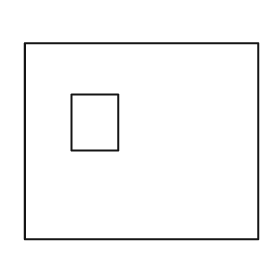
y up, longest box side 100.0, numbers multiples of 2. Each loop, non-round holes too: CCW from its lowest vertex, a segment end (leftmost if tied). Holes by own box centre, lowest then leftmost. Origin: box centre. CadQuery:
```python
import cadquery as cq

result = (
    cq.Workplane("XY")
    .moveTo(-50.0, -42.0)
    .lineTo(50.0, -42.0)
    .lineTo(50.0, 42.0)
    .lineTo(-50.0, 42.0)
    .close()
    .moveTo(-30.0, -4.0)
    .lineTo(-10.0, -4.0)
    .lineTo(-10.0, 20.0)
    .lineTo(-30.0, 20.0)
    .close()
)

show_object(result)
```